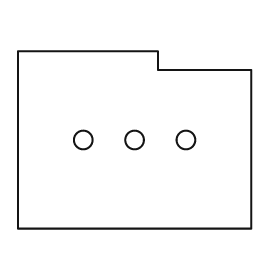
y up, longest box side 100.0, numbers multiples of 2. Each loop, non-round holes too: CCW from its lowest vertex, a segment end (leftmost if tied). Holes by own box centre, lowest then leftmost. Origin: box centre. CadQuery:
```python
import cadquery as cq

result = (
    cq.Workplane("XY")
    .moveTo(-50.0, -38.0)
    .lineTo(50.0, -38.0)
    .lineTo(50.0, 30.0)
    .lineTo(10.0, 30.0)
    .lineTo(10.0, 38.0)
    .lineTo(-50.0, 38.0)
    .close()
    .moveTo(-22.0, 0.0)
    .circle(4.0)
    .moveTo(0.0, 0.0)
    .circle(4.0)
    .moveTo(22.0, 0.0)
    .circle(4.0)
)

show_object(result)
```